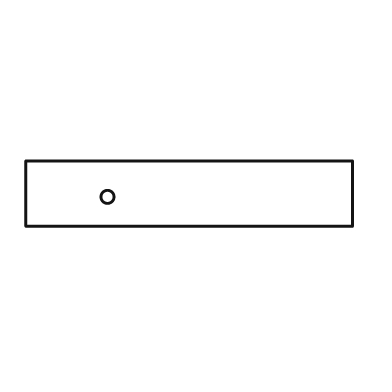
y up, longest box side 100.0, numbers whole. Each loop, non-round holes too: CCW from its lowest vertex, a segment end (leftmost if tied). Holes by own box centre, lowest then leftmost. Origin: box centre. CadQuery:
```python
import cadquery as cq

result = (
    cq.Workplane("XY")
    .moveTo(-50.0, -10.0)
    .lineTo(50.0, -10.0)
    .lineTo(50.0, 10.0)
    .lineTo(-50.0, 10.0)
    .close()
    .moveTo(-25.0, -1.0)
    .circle(2.0)
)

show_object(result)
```